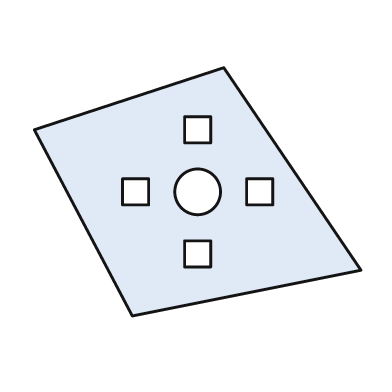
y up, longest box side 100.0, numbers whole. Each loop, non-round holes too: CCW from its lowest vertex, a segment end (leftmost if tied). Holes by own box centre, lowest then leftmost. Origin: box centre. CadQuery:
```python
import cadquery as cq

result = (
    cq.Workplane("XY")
    .moveTo(-20.0, -38.0)
    .lineTo(50.0, -24.0)
    .lineTo(8.0, 38.0)
    .lineTo(-50.0, 19.0)
    .close()
    .moveTo(-4.0, -23.0)
    .lineTo(4.0, -23.0)
    .lineTo(4.0, -15.0)
    .lineTo(-4.0, -15.0)
    .close()
    .moveTo(-23.0, -4.0)
    .lineTo(-15.0, -4.0)
    .lineTo(-15.0, 4.0)
    .lineTo(-23.0, 4.0)
    .close()
    .moveTo(0.0, 0.0)
    .circle(7.0)
    .moveTo(15.0, -4.0)
    .lineTo(23.0, -4.0)
    .lineTo(23.0, 4.0)
    .lineTo(15.0, 4.0)
    .close()
    .moveTo(-4.0, 15.0)
    .lineTo(4.0, 15.0)
    .lineTo(4.0, 23.0)
    .lineTo(-4.0, 23.0)
    .close()
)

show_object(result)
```